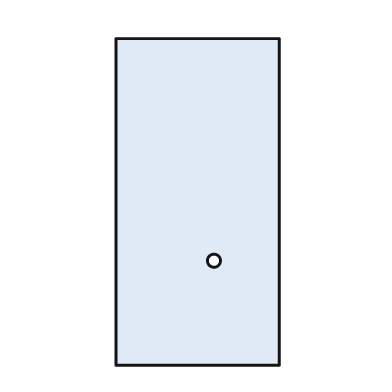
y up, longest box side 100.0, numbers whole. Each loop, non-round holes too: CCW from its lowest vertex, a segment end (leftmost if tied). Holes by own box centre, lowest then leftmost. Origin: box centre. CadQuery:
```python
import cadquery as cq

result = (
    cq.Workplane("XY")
    .moveTo(-25.0, -50.0)
    .lineTo(25.0, -50.0)
    .lineTo(25.0, 50.0)
    .lineTo(-25.0, 50.0)
    .close()
    .moveTo(5.0, -18.0)
    .circle(2.0)
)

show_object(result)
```